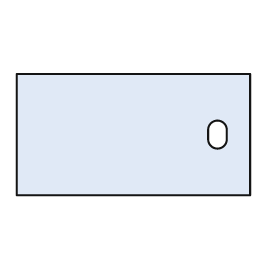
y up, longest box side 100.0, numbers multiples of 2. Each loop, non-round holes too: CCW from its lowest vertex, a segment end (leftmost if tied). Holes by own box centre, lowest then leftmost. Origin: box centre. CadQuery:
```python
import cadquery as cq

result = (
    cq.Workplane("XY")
    .moveTo(-50.0, -26.0)
    .lineTo(50.0, -26.0)
    .lineTo(50.0, 26.0)
    .lineTo(-50.0, 26.0)
    .close()
    .moveTo(32.0, -2.0)
    .threePointArc((36.0, -6.0), (40.0, -2.0))
    .lineTo(40.0, 2.0)
    .threePointArc((36.0, 6.0), (32.0, 2.0))
    .close()
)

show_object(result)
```